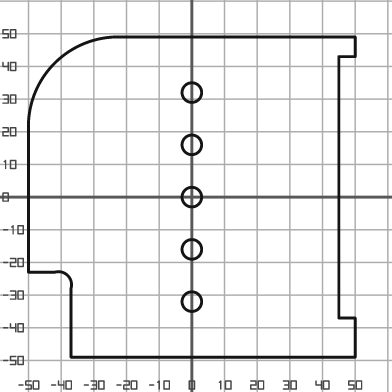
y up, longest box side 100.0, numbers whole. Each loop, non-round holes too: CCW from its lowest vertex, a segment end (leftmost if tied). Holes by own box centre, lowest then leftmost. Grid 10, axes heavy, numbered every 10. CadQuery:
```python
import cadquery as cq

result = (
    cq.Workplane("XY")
    .moveTo(-37.0, -49.0)
    .lineTo(50.0, -49.0)
    .lineTo(50.0, -37.0)
    .lineTo(45.0, -37.0)
    .lineTo(45.0, 43.0)
    .lineTo(50.0, 43.0)
    .lineTo(50.0, 49.0)
    .lineTo(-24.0, 49.0)
    .threePointArc((-42.0, 41.0), (-50.0, 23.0))
    .lineTo(-50.0, -23.0)
    .lineTo(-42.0, -23.0)
    .threePointArc((-38.0, -24.0), (-37.0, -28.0))
    .close()
    .moveTo(0.0, -32.0)
    .circle(3.0)
    .moveTo(0.0, -16.0)
    .circle(3.0)
    .moveTo(0.0, 0.0)
    .circle(3.0)
    .moveTo(0.0, 16.0)
    .circle(3.0)
    .moveTo(0.0, 32.0)
    .circle(3.0)
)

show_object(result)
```